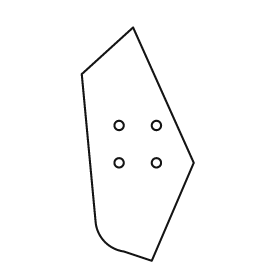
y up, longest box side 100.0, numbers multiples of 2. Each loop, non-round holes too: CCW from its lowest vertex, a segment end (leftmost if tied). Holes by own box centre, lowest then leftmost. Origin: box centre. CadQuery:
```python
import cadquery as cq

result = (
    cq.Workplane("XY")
    .moveTo(6.0, -50.0)
    .lineTo(24.0, -8.0)
    .lineTo(-2.0, 50.0)
    .lineTo(-24.0, 30.0)
    .lineTo(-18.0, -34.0)
    .threePointArc((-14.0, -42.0), (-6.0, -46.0))
    .close()
    .moveTo(-8.0, -8.0)
    .circle(2.0)
    .moveTo(8.0, -8.0)
    .circle(2.0)
    .moveTo(-8.0, 8.0)
    .circle(2.0)
    .moveTo(8.0, 8.0)
    .circle(2.0)
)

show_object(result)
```